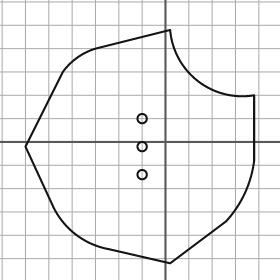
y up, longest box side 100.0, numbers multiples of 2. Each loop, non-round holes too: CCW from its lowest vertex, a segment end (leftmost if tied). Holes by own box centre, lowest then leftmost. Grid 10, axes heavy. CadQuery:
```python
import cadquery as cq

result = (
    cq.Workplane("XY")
    .moveTo(2.0, -52.0)
    .lineTo(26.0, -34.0)
    .threePointArc((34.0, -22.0), (38.0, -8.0))
    .lineTo(38.0, 20.0)
    .threePointArc((14.0, 26.0), (2.0, 48.0))
    .lineTo(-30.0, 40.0)
    .threePointArc((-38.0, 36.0), (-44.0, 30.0))
    .lineTo(-60.0, -2.0)
    .lineTo(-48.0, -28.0)
    .threePointArc((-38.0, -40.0), (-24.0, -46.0))
    .close()
    .moveTo(-10.0, -14.0)
    .circle(2.0)
    .moveTo(-10.0, -2.0)
    .circle(2.0)
    .moveTo(-10.0, 10.0)
    .circle(2.0)
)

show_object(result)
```